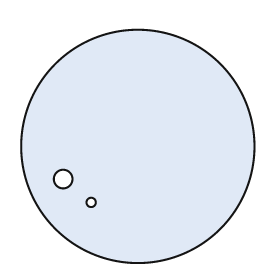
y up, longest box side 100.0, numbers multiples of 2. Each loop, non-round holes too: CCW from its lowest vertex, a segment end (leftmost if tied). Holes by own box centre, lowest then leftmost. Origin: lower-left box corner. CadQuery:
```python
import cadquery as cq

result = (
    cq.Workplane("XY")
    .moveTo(50.0, 50.0)
    .circle(50.0)
    .moveTo(30.0, 26.0)
    .circle(2.0)
    .moveTo(18.0, 36.0)
    .circle(4.0)
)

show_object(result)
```